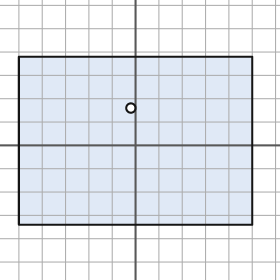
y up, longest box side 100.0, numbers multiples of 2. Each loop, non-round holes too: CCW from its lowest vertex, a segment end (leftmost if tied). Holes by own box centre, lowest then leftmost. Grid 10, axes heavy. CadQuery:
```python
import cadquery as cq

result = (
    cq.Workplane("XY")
    .moveTo(-50.0, -34.0)
    .lineTo(50.0, -34.0)
    .lineTo(50.0, 38.0)
    .lineTo(-50.0, 38.0)
    .close()
    .moveTo(-2.0, 16.0)
    .circle(2.0)
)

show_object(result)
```